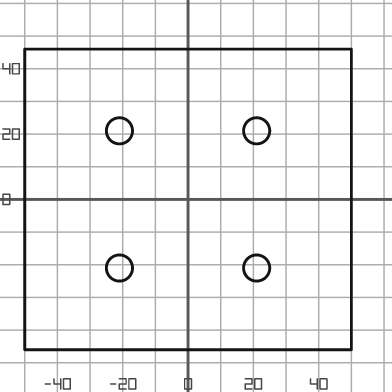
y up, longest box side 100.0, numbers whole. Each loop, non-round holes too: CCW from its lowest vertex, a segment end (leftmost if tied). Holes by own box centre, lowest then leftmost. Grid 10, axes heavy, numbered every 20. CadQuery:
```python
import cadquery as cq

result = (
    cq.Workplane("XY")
    .moveTo(-50.0, -46.0)
    .lineTo(50.0, -46.0)
    .lineTo(50.0, 46.0)
    .lineTo(-50.0, 46.0)
    .close()
    .moveTo(-21.0, -21.0)
    .circle(4.0)
    .moveTo(21.0, -21.0)
    .circle(4.0)
    .moveTo(-21.0, 21.0)
    .circle(4.0)
    .moveTo(21.0, 21.0)
    .circle(4.0)
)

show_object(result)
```